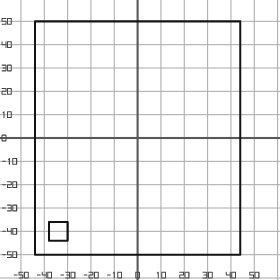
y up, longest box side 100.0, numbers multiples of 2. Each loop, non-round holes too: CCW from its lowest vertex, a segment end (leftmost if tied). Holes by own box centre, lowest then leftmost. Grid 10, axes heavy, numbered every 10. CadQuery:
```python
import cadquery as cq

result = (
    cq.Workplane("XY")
    .moveTo(-44.0, -50.0)
    .lineTo(44.0, -50.0)
    .lineTo(44.0, 50.0)
    .lineTo(-44.0, 50.0)
    .close()
    .moveTo(-38.0, -44.0)
    .lineTo(-30.0, -44.0)
    .lineTo(-30.0, -36.0)
    .lineTo(-38.0, -36.0)
    .close()
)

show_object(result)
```